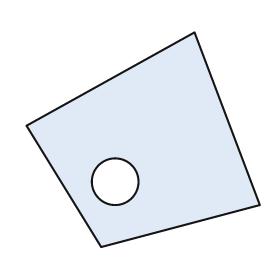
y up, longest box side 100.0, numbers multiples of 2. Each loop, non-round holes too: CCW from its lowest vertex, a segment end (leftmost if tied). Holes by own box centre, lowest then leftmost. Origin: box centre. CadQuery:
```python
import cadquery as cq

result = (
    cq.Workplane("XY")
    .moveTo(-18.0, -46.0)
    .lineTo(50.0, -28.0)
    .lineTo(22.0, 46.0)
    .lineTo(-50.0, 6.0)
    .close()
    .moveTo(-12.0, -18.0)
    .circle(10.0)
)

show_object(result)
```